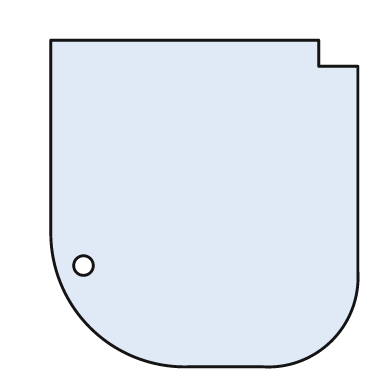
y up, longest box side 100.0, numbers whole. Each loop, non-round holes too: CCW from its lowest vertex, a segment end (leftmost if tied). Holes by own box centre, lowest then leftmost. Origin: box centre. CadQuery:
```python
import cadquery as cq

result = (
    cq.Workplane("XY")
    .moveTo(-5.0, -50.0)
    .lineTo(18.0, -50.0)
    .threePointArc((39.0, -42.0), (47.0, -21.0))
    .lineTo(47.0, 42.0)
    .lineTo(35.0, 42.0)
    .lineTo(35.0, 50.0)
    .lineTo(-47.0, 50.0)
    .lineTo(-47.0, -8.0)
    .threePointArc((-35.0, -38.0), (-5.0, -50.0))
    .close()
    .moveTo(-37.0, -19.0)
    .circle(3.0)
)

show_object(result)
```